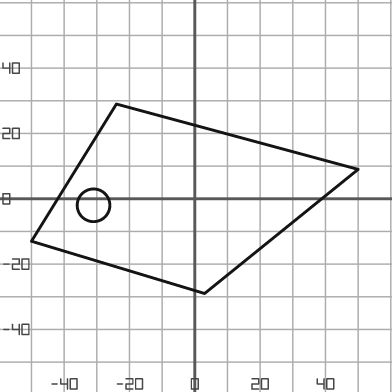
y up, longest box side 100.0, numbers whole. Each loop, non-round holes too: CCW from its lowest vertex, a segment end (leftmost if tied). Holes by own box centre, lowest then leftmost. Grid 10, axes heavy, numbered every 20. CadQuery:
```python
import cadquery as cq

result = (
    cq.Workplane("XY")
    .moveTo(3.0, -29.0)
    .lineTo(50.0, 9.0)
    .lineTo(-24.0, 29.0)
    .lineTo(-50.0, -13.0)
    .close()
    .moveTo(-31.0, -2.0)
    .circle(5.0)
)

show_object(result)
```